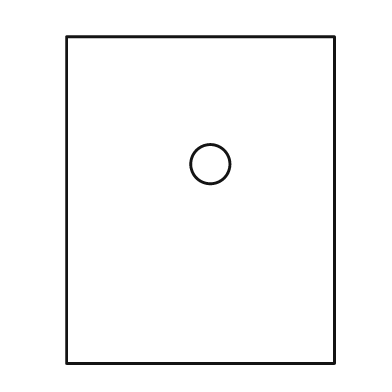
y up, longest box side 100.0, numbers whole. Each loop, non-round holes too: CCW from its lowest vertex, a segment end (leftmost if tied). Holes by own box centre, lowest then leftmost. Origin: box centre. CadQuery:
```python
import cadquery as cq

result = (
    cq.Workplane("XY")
    .moveTo(-41.0, -50.0)
    .lineTo(41.0, -50.0)
    .lineTo(41.0, 50.0)
    .lineTo(-41.0, 50.0)
    .close()
    .moveTo(3.0, 11.0)
    .circle(6.0)
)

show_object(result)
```